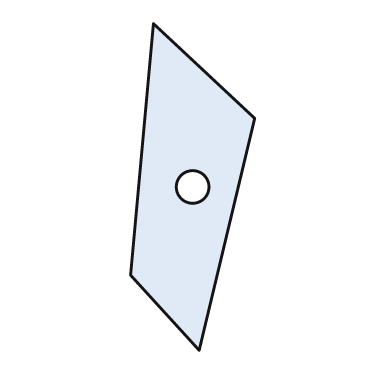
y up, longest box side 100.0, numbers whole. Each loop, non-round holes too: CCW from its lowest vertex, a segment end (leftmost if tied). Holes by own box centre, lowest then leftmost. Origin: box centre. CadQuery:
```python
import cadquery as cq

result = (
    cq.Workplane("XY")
    .moveTo(2.0, -50.0)
    .lineTo(19.0, 21.0)
    .lineTo(-12.0, 50.0)
    .lineTo(-19.0, -27.0)
    .close()
    .moveTo(0.0, 0.0)
    .circle(5.0)
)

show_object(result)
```